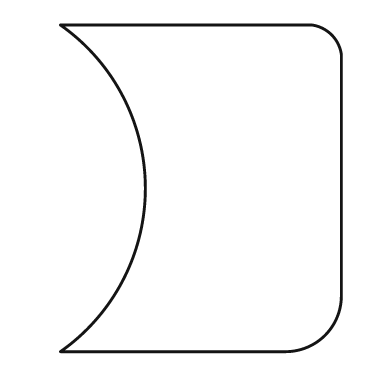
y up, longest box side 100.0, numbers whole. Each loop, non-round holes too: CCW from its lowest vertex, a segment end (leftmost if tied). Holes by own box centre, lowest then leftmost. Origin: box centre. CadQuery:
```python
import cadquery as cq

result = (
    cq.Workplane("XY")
    .moveTo(-43.0, -50.0)
    .lineTo(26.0, -50.0)
    .threePointArc((38.0, -45.0), (43.0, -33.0))
    .lineTo(43.0, 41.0)
    .threePointArc((40.0, 47.0), (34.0, 50.0))
    .lineTo(-43.0, 50.0)
    .threePointArc((-17.0, 0.0), (-43.0, -50.0))
    .close()
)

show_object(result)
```